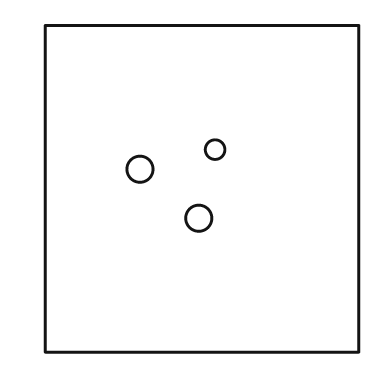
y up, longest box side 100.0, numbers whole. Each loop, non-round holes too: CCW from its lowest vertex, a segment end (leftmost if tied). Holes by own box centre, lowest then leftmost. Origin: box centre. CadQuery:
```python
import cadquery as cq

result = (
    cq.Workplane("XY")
    .moveTo(-48.0, -50.0)
    .lineTo(48.0, -50.0)
    .lineTo(48.0, 50.0)
    .lineTo(-48.0, 50.0)
    .close()
    .moveTo(-1.0, -9.0)
    .circle(4.0)
    .moveTo(-19.0, 6.0)
    .circle(4.0)
    .moveTo(4.0, 12.0)
    .circle(3.0)
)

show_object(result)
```